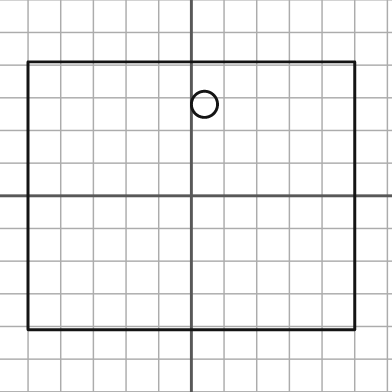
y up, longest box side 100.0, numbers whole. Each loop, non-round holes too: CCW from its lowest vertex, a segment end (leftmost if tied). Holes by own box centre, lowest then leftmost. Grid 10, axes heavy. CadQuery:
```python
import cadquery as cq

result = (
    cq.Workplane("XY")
    .moveTo(-50.0, -41.0)
    .lineTo(50.0, -41.0)
    .lineTo(50.0, 41.0)
    .lineTo(-50.0, 41.0)
    .close()
    .moveTo(4.0, 28.0)
    .circle(4.0)
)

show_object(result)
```